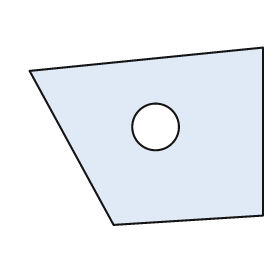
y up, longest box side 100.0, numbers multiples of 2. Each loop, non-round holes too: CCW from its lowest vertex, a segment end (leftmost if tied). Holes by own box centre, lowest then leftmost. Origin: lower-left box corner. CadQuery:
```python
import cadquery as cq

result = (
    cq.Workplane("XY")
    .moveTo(36.0, 0.0)
    .lineTo(100.0, 4.0)
    .lineTo(100.0, 76.0)
    .lineTo(0.0, 66.0)
    .close()
    .moveTo(54.0, 42.0)
    .circle(10.0)
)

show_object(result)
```